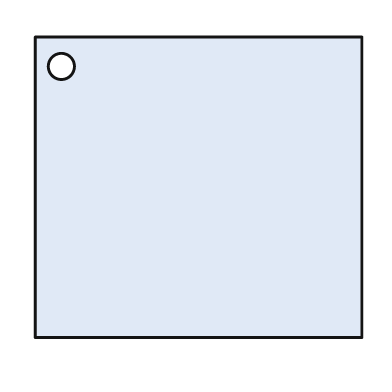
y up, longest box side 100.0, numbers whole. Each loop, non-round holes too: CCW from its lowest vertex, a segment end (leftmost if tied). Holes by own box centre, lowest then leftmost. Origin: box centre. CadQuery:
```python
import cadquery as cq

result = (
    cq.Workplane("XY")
    .moveTo(-50.0, -46.0)
    .lineTo(50.0, -46.0)
    .lineTo(50.0, 46.0)
    .lineTo(-50.0, 46.0)
    .close()
    .moveTo(-42.0, 37.0)
    .circle(4.0)
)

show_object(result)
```